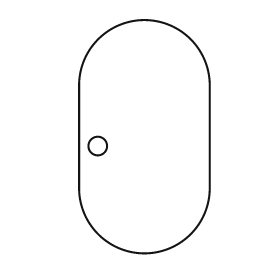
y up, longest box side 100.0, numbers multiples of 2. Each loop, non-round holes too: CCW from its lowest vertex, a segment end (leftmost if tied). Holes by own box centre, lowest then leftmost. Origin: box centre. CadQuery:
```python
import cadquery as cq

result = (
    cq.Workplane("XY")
    .moveTo(-28.0, -22.0)
    .threePointArc((0.0, -50.0), (28.0, -22.0))
    .lineTo(28.0, 22.0)
    .threePointArc((0.0, 50.0), (-28.0, 22.0))
    .close()
    .moveTo(-20.0, -4.0)
    .circle(4.0)
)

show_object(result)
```